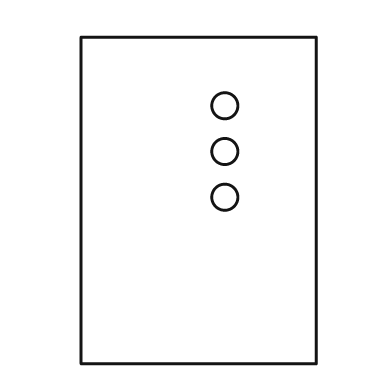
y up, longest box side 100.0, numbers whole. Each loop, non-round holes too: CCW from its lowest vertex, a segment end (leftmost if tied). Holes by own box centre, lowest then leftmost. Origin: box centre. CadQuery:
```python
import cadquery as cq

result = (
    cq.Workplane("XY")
    .moveTo(-36.0, -50.0)
    .lineTo(36.0, -50.0)
    .lineTo(36.0, 50.0)
    .lineTo(-36.0, 50.0)
    .close()
    .moveTo(8.0, 1.0)
    .circle(4.0)
    .moveTo(8.0, 15.0)
    .circle(4.0)
    .moveTo(8.0, 29.0)
    .circle(4.0)
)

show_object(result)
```